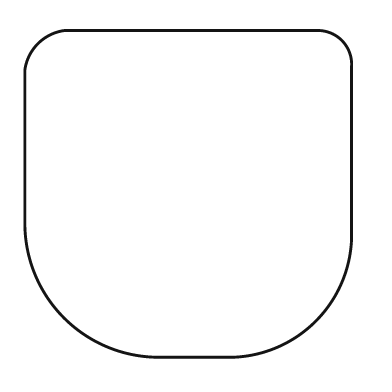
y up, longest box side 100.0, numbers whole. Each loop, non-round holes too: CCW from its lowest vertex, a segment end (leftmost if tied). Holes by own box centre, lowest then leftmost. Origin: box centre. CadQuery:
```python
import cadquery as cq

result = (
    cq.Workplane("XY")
    .moveTo(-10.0, -50.0)
    .lineTo(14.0, -50.0)
    .threePointArc((39.0, -39.0), (50.0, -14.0))
    .lineTo(50.0, 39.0)
    .threePointArc((47.0, 47.0), (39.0, 50.0))
    .lineTo(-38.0, 50.0)
    .threePointArc((-46.0, 46.0), (-50.0, 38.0))
    .lineTo(-50.0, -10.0)
    .threePointArc((-38.0, -38.0), (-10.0, -50.0))
    .close()
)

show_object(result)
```